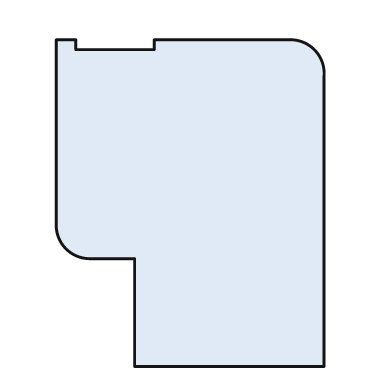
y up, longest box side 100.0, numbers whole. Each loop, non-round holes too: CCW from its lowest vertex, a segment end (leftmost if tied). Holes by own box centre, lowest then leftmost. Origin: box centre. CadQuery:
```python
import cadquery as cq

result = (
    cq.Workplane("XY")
    .moveTo(-17.0, -50.0)
    .lineTo(41.0, -50.0)
    .lineTo(41.0, 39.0)
    .threePointArc((38.0, 47.0), (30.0, 50.0))
    .lineTo(-11.0, 50.0)
    .lineTo(-11.0, 47.0)
    .lineTo(-35.0, 47.0)
    .lineTo(-35.0, 50.0)
    .lineTo(-41.0, 50.0)
    .lineTo(-41.0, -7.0)
    .threePointArc((-38.0, -14.0), (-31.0, -17.0))
    .lineTo(-17.0, -17.0)
    .close()
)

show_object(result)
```